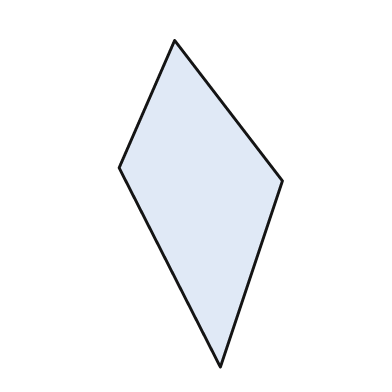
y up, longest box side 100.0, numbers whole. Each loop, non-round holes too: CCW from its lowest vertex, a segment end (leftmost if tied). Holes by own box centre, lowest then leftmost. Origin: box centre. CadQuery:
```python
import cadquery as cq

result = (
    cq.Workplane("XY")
    .moveTo(6.0, -50.0)
    .lineTo(25.0, 7.0)
    .lineTo(-8.0, 50.0)
    .lineTo(-25.0, 11.0)
    .close()
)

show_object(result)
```